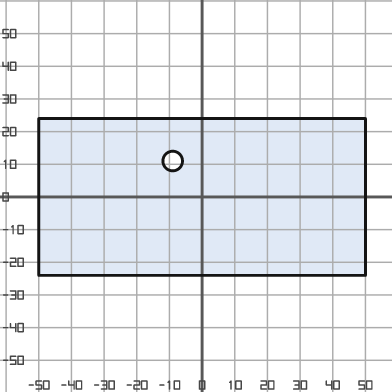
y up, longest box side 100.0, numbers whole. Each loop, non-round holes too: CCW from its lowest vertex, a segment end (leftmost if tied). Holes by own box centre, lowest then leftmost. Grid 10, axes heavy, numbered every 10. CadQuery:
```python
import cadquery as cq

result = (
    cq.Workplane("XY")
    .moveTo(-50.0, -24.0)
    .lineTo(50.0, -24.0)
    .lineTo(50.0, 24.0)
    .lineTo(-50.0, 24.0)
    .close()
    .moveTo(-9.0, 11.0)
    .circle(3.0)
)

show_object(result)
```